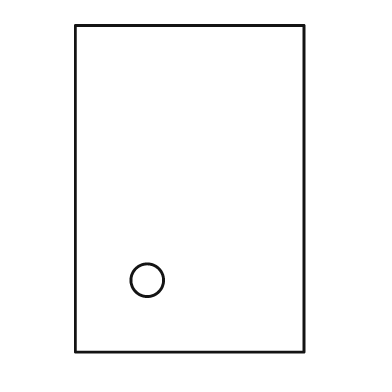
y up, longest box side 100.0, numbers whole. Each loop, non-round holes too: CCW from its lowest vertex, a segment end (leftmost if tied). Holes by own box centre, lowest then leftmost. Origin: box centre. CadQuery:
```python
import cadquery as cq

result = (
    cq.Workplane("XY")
    .moveTo(-35.0, -50.0)
    .lineTo(35.0, -50.0)
    .lineTo(35.0, 50.0)
    .lineTo(-35.0, 50.0)
    .close()
    .moveTo(-13.0, -28.0)
    .circle(5.0)
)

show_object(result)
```